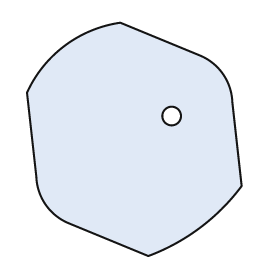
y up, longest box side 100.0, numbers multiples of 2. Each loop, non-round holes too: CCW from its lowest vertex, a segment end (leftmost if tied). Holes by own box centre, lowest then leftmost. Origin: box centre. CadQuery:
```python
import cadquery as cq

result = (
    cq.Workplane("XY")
    .moveTo(6.0, -50.0)
    .threePointArc((28.0, -38.0), (46.0, -20.0))
    .lineTo(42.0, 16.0)
    .threePointArc((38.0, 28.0), (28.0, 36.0))
    .lineTo(-6.0, 50.0)
    .threePointArc((-30.0, 40.0), (-46.0, 20.0))
    .lineTo(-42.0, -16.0)
    .threePointArc((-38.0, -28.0), (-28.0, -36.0))
    .close()
    .moveTo(16.0, 10.0)
    .circle(4.0)
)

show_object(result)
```